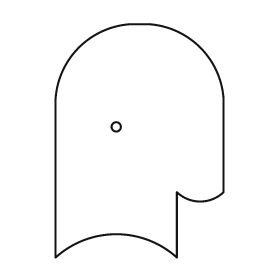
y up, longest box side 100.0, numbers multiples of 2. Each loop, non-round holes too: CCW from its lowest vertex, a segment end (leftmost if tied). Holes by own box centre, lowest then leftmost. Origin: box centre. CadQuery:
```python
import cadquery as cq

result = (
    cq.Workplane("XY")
    .moveTo(-36.0, -50.0)
    .threePointArc((-10.0, -40.0), (16.0, -50.0))
    .lineTo(16.0, -22.0)
    .threePointArc((26.0, -26.0), (36.0, -22.0))
    .lineTo(36.0, 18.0)
    .threePointArc((26.0, 40.0), (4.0, 50.0))
    .lineTo(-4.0, 50.0)
    .threePointArc((-26.0, 40.0), (-36.0, 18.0))
    .close()
    .moveTo(-10.0, 6.0)
    .circle(2.0)
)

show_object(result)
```